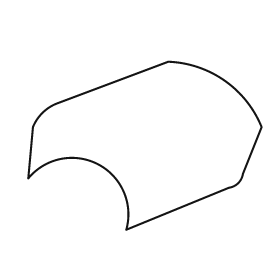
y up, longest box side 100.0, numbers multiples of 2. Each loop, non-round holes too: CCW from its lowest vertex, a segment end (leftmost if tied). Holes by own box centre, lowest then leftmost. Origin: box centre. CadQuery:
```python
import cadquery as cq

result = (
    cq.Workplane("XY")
    .moveTo(-8.0, -36.0)
    .lineTo(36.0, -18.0)
    .threePointArc((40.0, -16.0), (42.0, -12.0))
    .lineTo(50.0, 8.0)
    .threePointArc((34.0, 28.0), (10.0, 36.0))
    .lineTo(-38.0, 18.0)
    .threePointArc((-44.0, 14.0), (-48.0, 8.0))
    .lineTo(-50.0, -14.0)
    .threePointArc((-20.0, -8.0), (-8.0, -36.0))
    .close()
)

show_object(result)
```